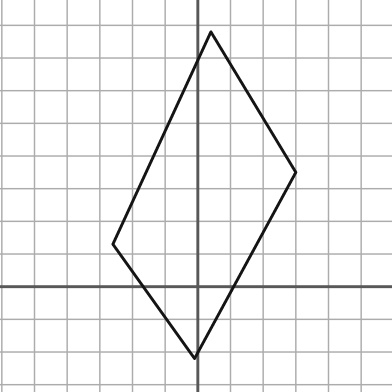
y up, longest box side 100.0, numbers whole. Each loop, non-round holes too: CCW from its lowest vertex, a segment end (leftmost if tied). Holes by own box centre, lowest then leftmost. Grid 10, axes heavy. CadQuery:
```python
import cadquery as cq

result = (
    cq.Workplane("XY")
    .moveTo(-1.0, -22.0)
    .lineTo(30.0, 35.0)
    .lineTo(4.0, 78.0)
    .lineTo(-26.0, 13.0)
    .close()
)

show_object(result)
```